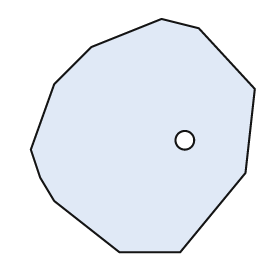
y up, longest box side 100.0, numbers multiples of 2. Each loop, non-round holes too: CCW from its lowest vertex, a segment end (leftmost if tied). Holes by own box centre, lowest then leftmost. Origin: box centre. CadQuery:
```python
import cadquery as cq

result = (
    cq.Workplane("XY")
    .moveTo(-10.0, -50.0)
    .lineTo(16.0, -50.0)
    .lineTo(44.0, -16.0)
    .lineTo(48.0, 20.0)
    .lineTo(24.0, 46.0)
    .lineTo(8.0, 50.0)
    .lineTo(-22.0, 38.0)
    .lineTo(-38.0, 22.0)
    .lineTo(-48.0, -6.0)
    .lineTo(-44.0, -18.0)
    .lineTo(-38.0, -28.0)
    .close()
    .moveTo(18.0, -2.0)
    .circle(4.0)
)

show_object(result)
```